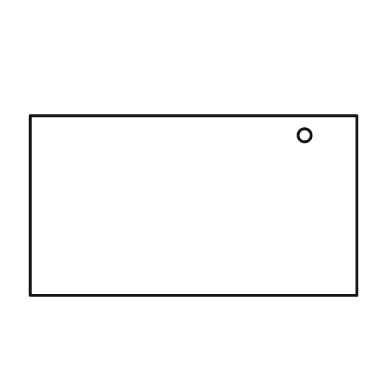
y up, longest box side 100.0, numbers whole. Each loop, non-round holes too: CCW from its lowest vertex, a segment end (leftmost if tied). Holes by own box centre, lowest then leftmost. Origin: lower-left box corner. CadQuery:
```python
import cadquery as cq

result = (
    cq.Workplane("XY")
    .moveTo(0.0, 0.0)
    .lineTo(100.0, 0.0)
    .lineTo(100.0, 55.0)
    .lineTo(0.0, 55.0)
    .close()
    .moveTo(84.0, 49.0)
    .circle(2.0)
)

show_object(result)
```